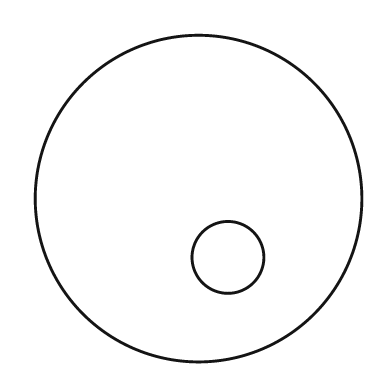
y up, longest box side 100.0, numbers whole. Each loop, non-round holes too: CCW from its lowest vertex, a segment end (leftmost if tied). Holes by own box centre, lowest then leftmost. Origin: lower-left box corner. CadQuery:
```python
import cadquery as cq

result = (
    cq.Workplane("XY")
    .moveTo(50.0, 50.0)
    .circle(50.0)
    .moveTo(59.0, 32.0)
    .circle(11.0)
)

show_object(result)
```